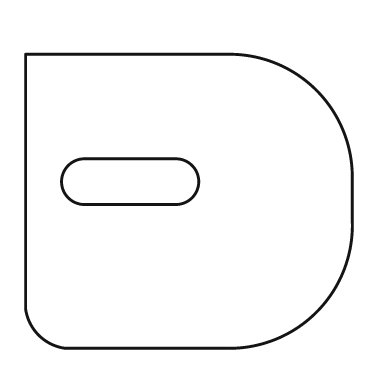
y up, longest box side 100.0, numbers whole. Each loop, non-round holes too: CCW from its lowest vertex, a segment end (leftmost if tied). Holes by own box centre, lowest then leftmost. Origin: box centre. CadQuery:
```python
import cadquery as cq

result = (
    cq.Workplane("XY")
    .moveTo(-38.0, -45.0)
    .lineTo(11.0, -45.0)
    .threePointArc((39.0, -34.0), (50.0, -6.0))
    .lineTo(50.0, 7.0)
    .threePointArc((39.0, 34.0), (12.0, 45.0))
    .lineTo(-50.0, 45.0)
    .lineTo(-50.0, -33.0)
    .threePointArc((-46.0, -41.0), (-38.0, -45.0))
    .close()
    .moveTo(-32.0, -1.0)
    .lineTo(-4.0, -1.0)
    .threePointArc((3.0, 6.0), (-4.0, 13.0))
    .lineTo(-32.0, 13.0)
    .threePointArc((-39.0, 6.0), (-32.0, -1.0))
    .close()
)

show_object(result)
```